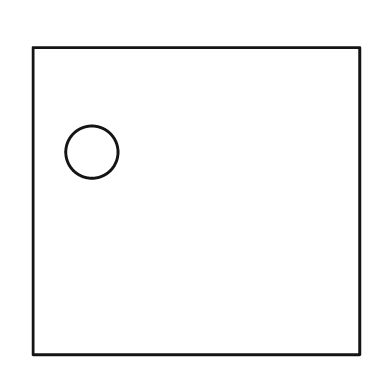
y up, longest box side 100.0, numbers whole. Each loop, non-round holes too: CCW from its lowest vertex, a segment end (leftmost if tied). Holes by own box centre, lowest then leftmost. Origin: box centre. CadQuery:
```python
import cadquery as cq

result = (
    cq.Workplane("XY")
    .moveTo(-50.0, -47.0)
    .lineTo(50.0, -47.0)
    .lineTo(50.0, 47.0)
    .lineTo(-50.0, 47.0)
    .close()
    .moveTo(-32.0, 15.0)
    .circle(8.0)
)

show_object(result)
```